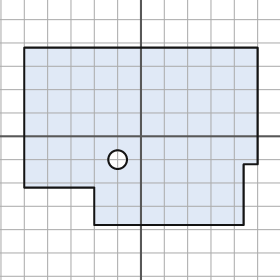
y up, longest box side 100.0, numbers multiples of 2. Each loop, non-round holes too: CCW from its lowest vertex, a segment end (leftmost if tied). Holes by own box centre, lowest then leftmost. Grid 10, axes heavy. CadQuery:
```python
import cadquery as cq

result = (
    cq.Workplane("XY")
    .moveTo(-20.0, -38.0)
    .lineTo(44.0, -38.0)
    .lineTo(44.0, -12.0)
    .lineTo(50.0, -12.0)
    .lineTo(50.0, 38.0)
    .lineTo(-50.0, 38.0)
    .lineTo(-50.0, -22.0)
    .lineTo(-20.0, -22.0)
    .close()
    .moveTo(-10.0, -10.0)
    .circle(4.0)
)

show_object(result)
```